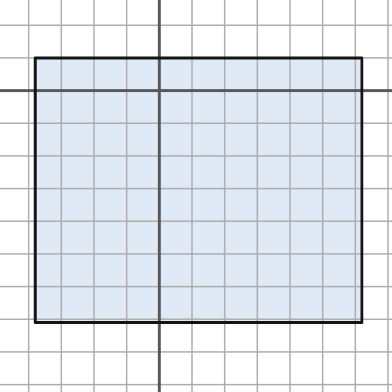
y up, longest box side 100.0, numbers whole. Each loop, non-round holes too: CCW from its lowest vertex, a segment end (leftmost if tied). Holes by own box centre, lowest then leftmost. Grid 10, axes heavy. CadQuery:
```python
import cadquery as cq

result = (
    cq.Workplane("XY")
    .moveTo(-38.0, -71.0)
    .lineTo(62.0, -71.0)
    .lineTo(62.0, 10.0)
    .lineTo(-38.0, 10.0)
    .close()
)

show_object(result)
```